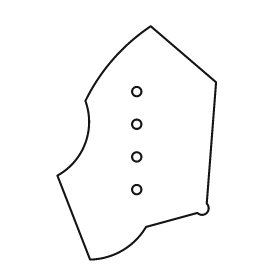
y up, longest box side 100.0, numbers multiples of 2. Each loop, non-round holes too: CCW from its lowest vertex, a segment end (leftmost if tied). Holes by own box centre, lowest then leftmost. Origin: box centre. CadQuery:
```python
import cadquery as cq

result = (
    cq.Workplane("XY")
    .moveTo(-20.0, -50.0)
    .threePointArc((-6.0, -46.0), (4.0, -36.0))
    .lineTo(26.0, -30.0)
    .threePointArc((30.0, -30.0), (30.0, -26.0))
    .lineTo(34.0, 26.0)
    .lineTo(6.0, 50.0)
    .threePointArc((-10.0, 36.0), (-22.0, 18.0))
    .threePointArc((-22.0, 0.0), (-34.0, -14.0))
    .close()
    .moveTo(0.0, -20.0)
    .circle(2.0)
    .moveTo(0.0, -6.0)
    .circle(2.0)
    .moveTo(0.0, 8.0)
    .circle(2.0)
    .moveTo(0.0, 22.0)
    .circle(2.0)
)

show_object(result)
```